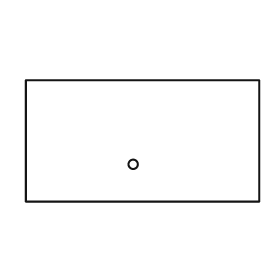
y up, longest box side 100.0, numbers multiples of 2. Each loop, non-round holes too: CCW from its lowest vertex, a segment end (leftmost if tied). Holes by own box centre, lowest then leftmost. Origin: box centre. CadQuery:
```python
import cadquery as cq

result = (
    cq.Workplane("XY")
    .moveTo(-50.0, -26.0)
    .lineTo(50.0, -26.0)
    .lineTo(50.0, 26.0)
    .lineTo(-50.0, 26.0)
    .close()
    .moveTo(-4.0, -10.0)
    .circle(2.0)
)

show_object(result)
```